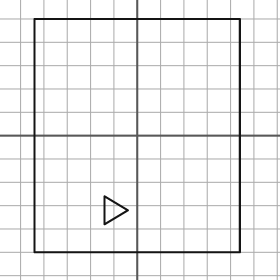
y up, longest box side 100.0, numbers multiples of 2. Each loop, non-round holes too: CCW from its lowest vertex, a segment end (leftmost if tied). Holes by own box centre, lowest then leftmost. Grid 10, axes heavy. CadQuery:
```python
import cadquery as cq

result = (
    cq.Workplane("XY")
    .moveTo(-44.0, -50.0)
    .lineTo(44.0, -50.0)
    .lineTo(44.0, 50.0)
    .lineTo(-44.0, 50.0)
    .close()
    .moveTo(-14.0, -38.0)
    .lineTo(-4.0, -32.0)
    .lineTo(-14.0, -26.0)
    .close()
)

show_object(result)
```